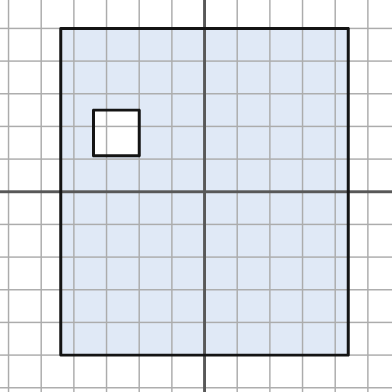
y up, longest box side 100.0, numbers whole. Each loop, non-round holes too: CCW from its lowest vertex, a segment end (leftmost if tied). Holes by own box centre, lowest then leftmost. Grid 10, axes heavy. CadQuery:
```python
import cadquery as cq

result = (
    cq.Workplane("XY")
    .moveTo(-44.0, -50.0)
    .lineTo(44.0, -50.0)
    .lineTo(44.0, 50.0)
    .lineTo(-44.0, 50.0)
    .close()
    .moveTo(-34.0, 11.0)
    .lineTo(-20.0, 11.0)
    .lineTo(-20.0, 25.0)
    .lineTo(-34.0, 25.0)
    .close()
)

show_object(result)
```